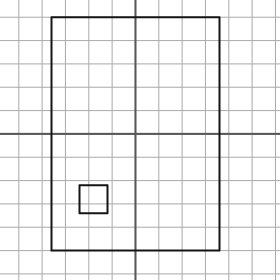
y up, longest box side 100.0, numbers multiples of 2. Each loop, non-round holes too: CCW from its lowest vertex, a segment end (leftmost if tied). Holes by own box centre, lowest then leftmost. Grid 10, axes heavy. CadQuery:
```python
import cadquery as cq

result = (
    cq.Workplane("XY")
    .moveTo(-36.0, -50.0)
    .lineTo(36.0, -50.0)
    .lineTo(36.0, 50.0)
    .lineTo(-36.0, 50.0)
    .close()
    .moveTo(-24.0, -34.0)
    .lineTo(-12.0, -34.0)
    .lineTo(-12.0, -22.0)
    .lineTo(-24.0, -22.0)
    .close()
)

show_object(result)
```